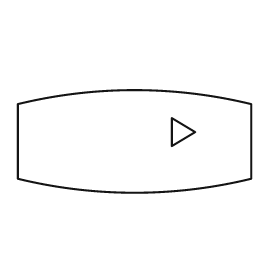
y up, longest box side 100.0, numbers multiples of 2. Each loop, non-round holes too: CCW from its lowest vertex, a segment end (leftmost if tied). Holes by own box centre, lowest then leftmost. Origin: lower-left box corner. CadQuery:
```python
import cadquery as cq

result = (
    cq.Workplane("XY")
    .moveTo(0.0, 6.0)
    .threePointArc((50.0, 0.0), (100.0, 6.0))
    .lineTo(100.0, 38.0)
    .threePointArc((50.0, 44.0), (0.0, 38.0))
    .close()
    .moveTo(66.0, 20.0)
    .lineTo(76.0, 26.0)
    .lineTo(66.0, 32.0)
    .close()
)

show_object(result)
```